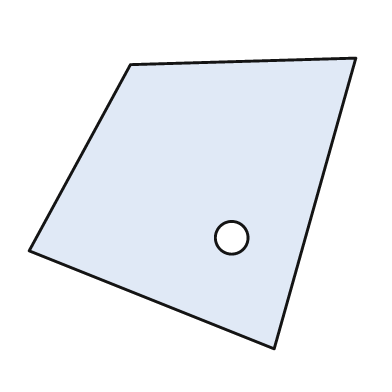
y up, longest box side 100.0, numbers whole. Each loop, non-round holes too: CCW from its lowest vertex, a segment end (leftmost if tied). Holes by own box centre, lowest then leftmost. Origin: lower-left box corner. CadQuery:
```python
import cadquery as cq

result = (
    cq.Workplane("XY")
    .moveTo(75.0, 0.0)
    .lineTo(100.0, 89.0)
    .lineTo(31.0, 87.0)
    .lineTo(0.0, 30.0)
    .close()
    .moveTo(62.0, 34.0)
    .circle(5.0)
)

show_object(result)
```